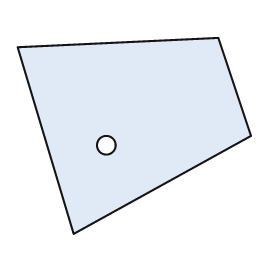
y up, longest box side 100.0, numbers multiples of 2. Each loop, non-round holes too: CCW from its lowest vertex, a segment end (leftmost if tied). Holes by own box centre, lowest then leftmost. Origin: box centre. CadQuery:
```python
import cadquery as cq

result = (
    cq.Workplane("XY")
    .moveTo(-26.0, -42.0)
    .lineTo(50.0, 0.0)
    .lineTo(36.0, 42.0)
    .lineTo(-50.0, 38.0)
    .close()
    .moveTo(-12.0, -4.0)
    .circle(4.0)
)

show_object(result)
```